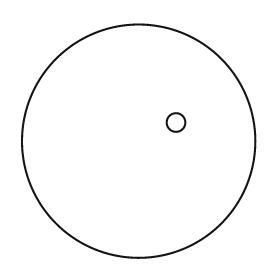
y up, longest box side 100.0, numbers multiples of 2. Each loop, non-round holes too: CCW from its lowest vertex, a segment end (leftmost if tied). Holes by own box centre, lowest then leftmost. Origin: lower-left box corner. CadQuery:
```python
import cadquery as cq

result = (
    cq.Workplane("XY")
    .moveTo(50.0, 50.0)
    .circle(50.0)
    .moveTo(66.0, 58.0)
    .circle(4.0)
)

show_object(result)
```